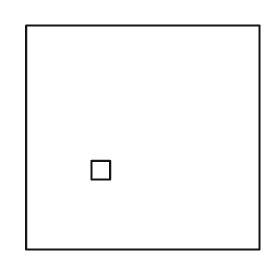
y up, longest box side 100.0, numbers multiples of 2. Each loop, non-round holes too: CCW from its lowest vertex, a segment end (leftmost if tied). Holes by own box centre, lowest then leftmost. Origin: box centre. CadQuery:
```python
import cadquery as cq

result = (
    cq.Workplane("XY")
    .moveTo(-50.0, -48.0)
    .lineTo(50.0, -48.0)
    .lineTo(50.0, 48.0)
    .lineTo(-50.0, 48.0)
    .close()
    .moveTo(-22.0, -18.0)
    .lineTo(-14.0, -18.0)
    .lineTo(-14.0, -10.0)
    .lineTo(-22.0, -10.0)
    .close()
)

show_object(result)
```